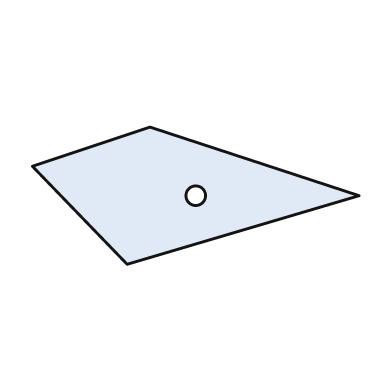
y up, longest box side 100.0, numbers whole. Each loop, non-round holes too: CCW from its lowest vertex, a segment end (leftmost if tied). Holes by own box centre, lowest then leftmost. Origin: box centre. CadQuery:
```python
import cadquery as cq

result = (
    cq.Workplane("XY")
    .moveTo(-21.0, -21.0)
    .lineTo(50.0, 0.0)
    .lineTo(-14.0, 21.0)
    .lineTo(-50.0, 9.0)
    .close()
    .moveTo(0.0, 0.0)
    .circle(3.0)
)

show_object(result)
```